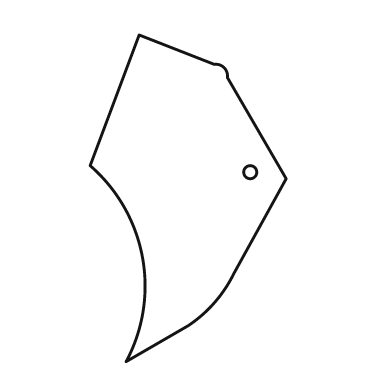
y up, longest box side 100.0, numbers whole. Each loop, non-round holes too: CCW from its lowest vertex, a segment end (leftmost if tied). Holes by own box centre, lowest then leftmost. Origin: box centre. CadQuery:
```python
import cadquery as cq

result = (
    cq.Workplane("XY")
    .moveTo(-19.0, -50.0)
    .lineTo(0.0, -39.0)
    .threePointArc((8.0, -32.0), (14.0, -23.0))
    .lineTo(30.0, 6.0)
    .lineTo(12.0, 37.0)
    .threePointArc((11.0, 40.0), (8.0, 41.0))
    .lineTo(-15.0, 50.0)
    .lineTo(-30.0, 10.0)
    .threePointArc((-14.0, -18.0), (-19.0, -50.0))
    .close()
    .moveTo(19.0, 8.0)
    .circle(2.0)
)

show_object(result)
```